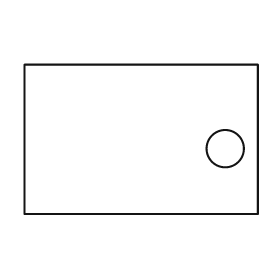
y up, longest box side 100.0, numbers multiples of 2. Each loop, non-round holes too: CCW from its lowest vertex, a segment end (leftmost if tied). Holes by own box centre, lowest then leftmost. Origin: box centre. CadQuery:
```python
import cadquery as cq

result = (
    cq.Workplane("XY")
    .moveTo(-50.0, -32.0)
    .lineTo(50.0, -32.0)
    .lineTo(50.0, 32.0)
    .lineTo(-50.0, 32.0)
    .close()
    .moveTo(36.0, -4.0)
    .circle(8.0)
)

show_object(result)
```